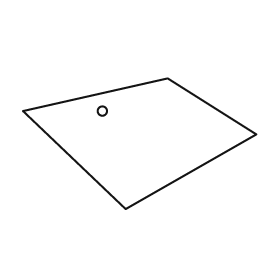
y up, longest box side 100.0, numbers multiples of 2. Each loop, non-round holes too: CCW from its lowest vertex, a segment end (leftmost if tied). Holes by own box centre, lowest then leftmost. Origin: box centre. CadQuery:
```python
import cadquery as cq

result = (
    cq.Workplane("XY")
    .moveTo(-6.0, -28.0)
    .lineTo(50.0, 4.0)
    .lineTo(12.0, 28.0)
    .lineTo(-50.0, 14.0)
    .close()
    .moveTo(-16.0, 14.0)
    .circle(2.0)
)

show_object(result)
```